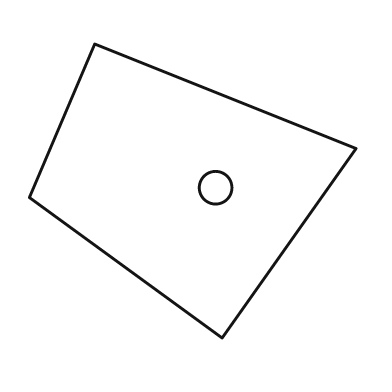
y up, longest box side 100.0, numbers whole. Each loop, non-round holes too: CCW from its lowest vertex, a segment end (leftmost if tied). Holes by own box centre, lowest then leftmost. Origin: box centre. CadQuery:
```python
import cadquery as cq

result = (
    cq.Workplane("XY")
    .moveTo(9.0, -45.0)
    .lineTo(50.0, 13.0)
    .lineTo(-30.0, 45.0)
    .lineTo(-50.0, -2.0)
    .close()
    .moveTo(7.0, 1.0)
    .circle(5.0)
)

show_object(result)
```